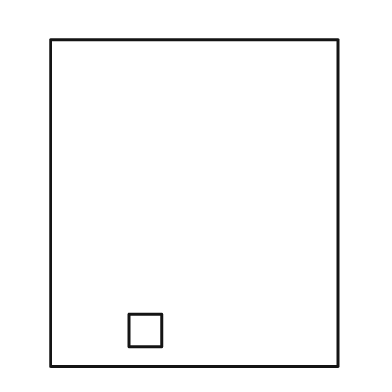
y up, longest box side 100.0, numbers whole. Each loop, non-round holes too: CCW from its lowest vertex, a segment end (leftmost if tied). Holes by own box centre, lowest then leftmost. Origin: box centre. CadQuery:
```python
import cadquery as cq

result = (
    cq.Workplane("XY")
    .moveTo(-44.0, -50.0)
    .lineTo(44.0, -50.0)
    .lineTo(44.0, 50.0)
    .lineTo(-44.0, 50.0)
    .close()
    .moveTo(-20.0, -44.0)
    .lineTo(-10.0, -44.0)
    .lineTo(-10.0, -34.0)
    .lineTo(-20.0, -34.0)
    .close()
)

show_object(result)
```